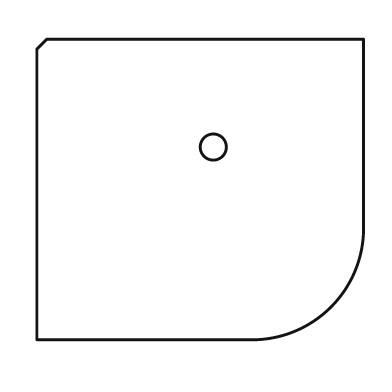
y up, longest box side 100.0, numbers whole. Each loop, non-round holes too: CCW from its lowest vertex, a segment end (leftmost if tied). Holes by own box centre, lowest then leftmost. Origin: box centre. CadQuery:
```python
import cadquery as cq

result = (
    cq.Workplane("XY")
    .moveTo(-50.0, -46.0)
    .lineTo(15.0, -46.0)
    .threePointArc((40.0, -36.0), (50.0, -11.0))
    .lineTo(50.0, 46.0)
    .lineTo(-47.0, 46.0)
    .lineTo(-50.0, 43.0)
    .close()
    .moveTo(4.0, 13.0)
    .circle(4.0)
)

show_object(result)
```